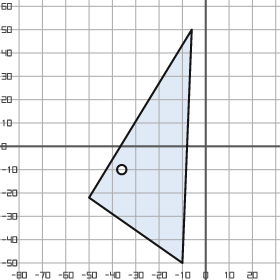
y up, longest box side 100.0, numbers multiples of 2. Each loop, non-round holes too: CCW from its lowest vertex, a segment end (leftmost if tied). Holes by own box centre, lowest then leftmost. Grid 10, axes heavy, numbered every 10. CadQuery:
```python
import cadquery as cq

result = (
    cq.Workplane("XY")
    .moveTo(-10.0, -50.0)
    .lineTo(-6.0, 50.0)
    .lineTo(-50.0, -22.0)
    .close()
    .moveTo(-36.0, -10.0)
    .circle(2.0)
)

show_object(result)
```